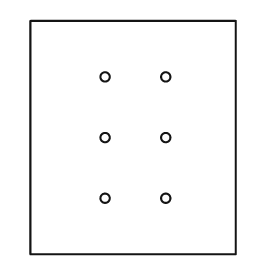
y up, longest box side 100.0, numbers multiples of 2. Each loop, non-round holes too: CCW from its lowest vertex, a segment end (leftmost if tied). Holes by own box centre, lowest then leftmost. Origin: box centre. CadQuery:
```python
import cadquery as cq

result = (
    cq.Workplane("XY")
    .moveTo(-44.0, -50.0)
    .lineTo(44.0, -50.0)
    .lineTo(44.0, 50.0)
    .lineTo(-44.0, 50.0)
    .close()
    .moveTo(-12.0, -26.0)
    .circle(2.0)
    .moveTo(14.0, -26.0)
    .circle(2.0)
    .moveTo(-12.0, 0.0)
    .circle(2.0)
    .moveTo(14.0, 0.0)
    .circle(2.0)
    .moveTo(-12.0, 26.0)
    .circle(2.0)
    .moveTo(14.0, 26.0)
    .circle(2.0)
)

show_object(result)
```